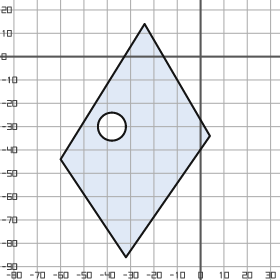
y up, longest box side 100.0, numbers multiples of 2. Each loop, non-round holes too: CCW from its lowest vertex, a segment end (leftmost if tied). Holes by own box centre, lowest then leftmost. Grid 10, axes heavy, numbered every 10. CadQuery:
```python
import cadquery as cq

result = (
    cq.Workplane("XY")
    .moveTo(-32.0, -86.0)
    .lineTo(4.0, -34.0)
    .lineTo(-24.0, 14.0)
    .lineTo(-60.0, -44.0)
    .close()
    .moveTo(-38.0, -30.0)
    .circle(6.0)
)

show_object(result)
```